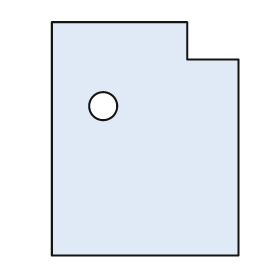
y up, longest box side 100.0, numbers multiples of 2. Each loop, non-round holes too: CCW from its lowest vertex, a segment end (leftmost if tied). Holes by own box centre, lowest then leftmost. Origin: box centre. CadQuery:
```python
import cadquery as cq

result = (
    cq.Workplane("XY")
    .moveTo(-40.0, -50.0)
    .lineTo(40.0, -50.0)
    .lineTo(40.0, 34.0)
    .lineTo(18.0, 34.0)
    .lineTo(18.0, 50.0)
    .lineTo(-40.0, 50.0)
    .close()
    .moveTo(-18.0, 14.0)
    .circle(6.0)
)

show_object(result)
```